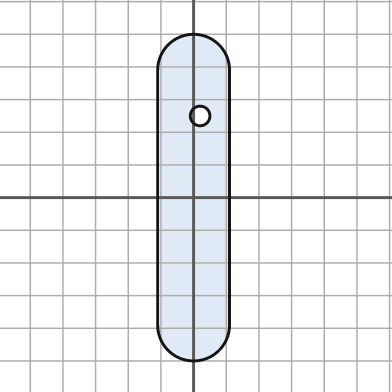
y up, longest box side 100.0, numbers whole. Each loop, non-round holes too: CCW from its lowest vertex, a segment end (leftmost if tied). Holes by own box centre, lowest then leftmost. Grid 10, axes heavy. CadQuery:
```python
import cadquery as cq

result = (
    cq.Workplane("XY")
    .moveTo(-11.0, -39.0)
    .threePointArc((0.0, -50.0), (11.0, -39.0))
    .lineTo(11.0, 39.0)
    .threePointArc((0.0, 50.0), (-11.0, 39.0))
    .close()
    .moveTo(2.0, 25.0)
    .circle(3.0)
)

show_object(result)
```